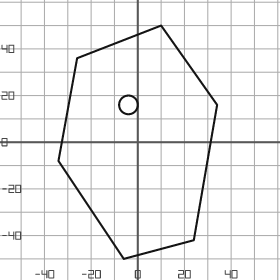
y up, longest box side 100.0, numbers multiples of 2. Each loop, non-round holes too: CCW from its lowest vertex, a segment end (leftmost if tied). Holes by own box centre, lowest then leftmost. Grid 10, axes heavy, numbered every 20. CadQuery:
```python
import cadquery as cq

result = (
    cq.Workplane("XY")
    .moveTo(-6.0, -50.0)
    .lineTo(24.0, -42.0)
    .lineTo(34.0, 16.0)
    .lineTo(10.0, 50.0)
    .lineTo(-26.0, 36.0)
    .lineTo(-34.0, -8.0)
    .close()
    .moveTo(-4.0, 16.0)
    .circle(4.0)
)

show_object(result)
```